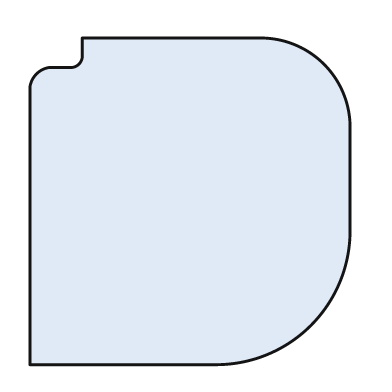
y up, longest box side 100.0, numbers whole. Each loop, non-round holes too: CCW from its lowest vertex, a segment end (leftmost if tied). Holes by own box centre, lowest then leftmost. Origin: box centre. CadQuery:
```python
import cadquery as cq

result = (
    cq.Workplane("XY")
    .moveTo(-49.0, -50.0)
    .lineTo(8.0, -50.0)
    .threePointArc((37.0, -38.0), (49.0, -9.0))
    .lineTo(49.0, 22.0)
    .threePointArc((41.0, 42.0), (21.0, 50.0))
    .lineTo(-33.0, 50.0)
    .lineTo(-33.0, 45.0)
    .threePointArc((-34.0, 42.0), (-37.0, 41.0))
    .lineTo(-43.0, 41.0)
    .threePointArc((-47.0, 39.0), (-49.0, 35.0))
    .close()
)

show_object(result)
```